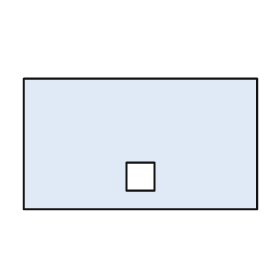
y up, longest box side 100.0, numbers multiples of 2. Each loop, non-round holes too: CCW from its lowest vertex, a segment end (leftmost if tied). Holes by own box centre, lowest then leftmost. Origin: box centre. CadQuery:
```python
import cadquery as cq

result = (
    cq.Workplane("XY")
    .moveTo(-50.0, -28.0)
    .lineTo(50.0, -28.0)
    .lineTo(50.0, 28.0)
    .lineTo(-50.0, 28.0)
    .close()
    .moveTo(-6.0, -20.0)
    .lineTo(6.0, -20.0)
    .lineTo(6.0, -8.0)
    .lineTo(-6.0, -8.0)
    .close()
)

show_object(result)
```